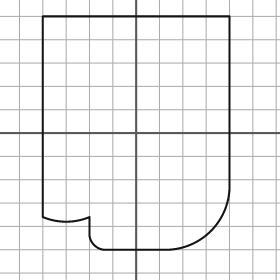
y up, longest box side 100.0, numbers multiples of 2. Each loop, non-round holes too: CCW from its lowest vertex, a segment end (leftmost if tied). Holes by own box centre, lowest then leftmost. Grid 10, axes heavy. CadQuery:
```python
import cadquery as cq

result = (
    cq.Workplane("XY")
    .moveTo(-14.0, -50.0)
    .lineTo(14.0, -50.0)
    .threePointArc((32.0, -42.0), (40.0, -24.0))
    .lineTo(40.0, 50.0)
    .lineTo(-40.0, 50.0)
    .lineTo(-40.0, -36.0)
    .threePointArc((-30.0, -38.0), (-20.0, -36.0))
    .lineTo(-20.0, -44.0)
    .threePointArc((-18.0, -48.0), (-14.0, -50.0))
    .close()
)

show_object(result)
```